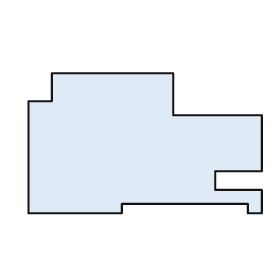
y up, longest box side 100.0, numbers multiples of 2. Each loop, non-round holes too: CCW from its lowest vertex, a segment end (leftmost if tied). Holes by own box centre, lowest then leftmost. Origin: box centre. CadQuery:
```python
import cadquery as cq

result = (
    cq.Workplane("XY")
    .moveTo(-50.0, -30.0)
    .lineTo(-10.0, -30.0)
    .lineTo(-10.0, -26.0)
    .lineTo(44.0, -26.0)
    .lineTo(44.0, -30.0)
    .lineTo(50.0, -30.0)
    .lineTo(50.0, -20.0)
    .lineTo(30.0, -20.0)
    .lineTo(30.0, -12.0)
    .lineTo(50.0, -12.0)
    .lineTo(50.0, 12.0)
    .lineTo(12.0, 12.0)
    .lineTo(12.0, 30.0)
    .lineTo(-40.0, 30.0)
    .lineTo(-40.0, 18.0)
    .lineTo(-50.0, 18.0)
    .close()
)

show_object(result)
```